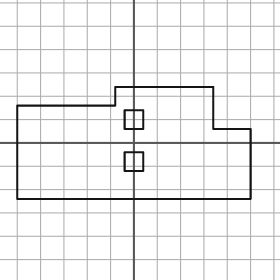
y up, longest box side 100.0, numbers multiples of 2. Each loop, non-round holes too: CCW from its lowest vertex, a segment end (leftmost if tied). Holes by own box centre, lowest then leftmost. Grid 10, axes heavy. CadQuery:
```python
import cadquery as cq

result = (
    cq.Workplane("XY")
    .moveTo(-50.0, -24.0)
    .lineTo(50.0, -24.0)
    .lineTo(50.0, 6.0)
    .lineTo(34.0, 6.0)
    .lineTo(34.0, 24.0)
    .lineTo(-8.0, 24.0)
    .lineTo(-8.0, 16.0)
    .lineTo(-50.0, 16.0)
    .close()
    .moveTo(-4.0, -12.0)
    .lineTo(4.0, -12.0)
    .lineTo(4.0, -4.0)
    .lineTo(-4.0, -4.0)
    .close()
    .moveTo(-4.0, 6.0)
    .lineTo(4.0, 6.0)
    .lineTo(4.0, 14.0)
    .lineTo(-4.0, 14.0)
    .close()
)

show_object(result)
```